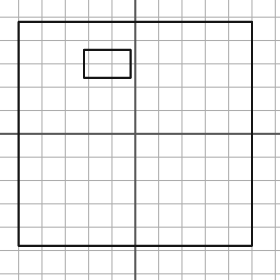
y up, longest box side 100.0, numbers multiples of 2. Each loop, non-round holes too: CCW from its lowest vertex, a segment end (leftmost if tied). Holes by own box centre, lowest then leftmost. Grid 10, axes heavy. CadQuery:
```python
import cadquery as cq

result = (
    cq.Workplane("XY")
    .moveTo(-50.0, -48.0)
    .lineTo(50.0, -48.0)
    .lineTo(50.0, 48.0)
    .lineTo(-50.0, 48.0)
    .close()
    .moveTo(-22.0, 24.0)
    .lineTo(-2.0, 24.0)
    .lineTo(-2.0, 36.0)
    .lineTo(-22.0, 36.0)
    .close()
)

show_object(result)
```